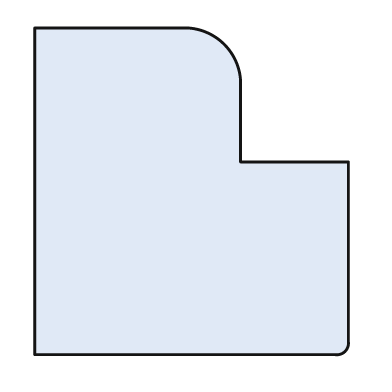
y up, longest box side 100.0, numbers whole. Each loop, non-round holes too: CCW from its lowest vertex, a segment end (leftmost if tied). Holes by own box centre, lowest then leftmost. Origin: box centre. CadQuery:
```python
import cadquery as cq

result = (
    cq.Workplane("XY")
    .moveTo(-48.0, -50.0)
    .lineTo(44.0, -50.0)
    .threePointArc((47.0, -49.0), (48.0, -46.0))
    .lineTo(48.0, 9.0)
    .lineTo(15.0, 9.0)
    .lineTo(15.0, 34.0)
    .threePointArc((10.0, 45.0), (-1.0, 50.0))
    .lineTo(-48.0, 50.0)
    .close()
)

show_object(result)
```